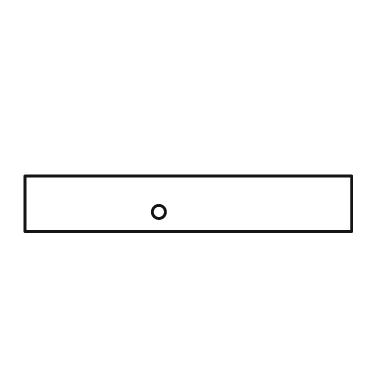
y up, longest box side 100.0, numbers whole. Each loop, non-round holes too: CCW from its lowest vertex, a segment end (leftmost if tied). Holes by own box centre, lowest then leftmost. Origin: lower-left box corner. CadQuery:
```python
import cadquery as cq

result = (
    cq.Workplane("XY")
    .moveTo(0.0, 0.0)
    .lineTo(100.0, 0.0)
    .lineTo(100.0, 17.0)
    .lineTo(0.0, 17.0)
    .close()
    .moveTo(41.0, 6.0)
    .circle(2.0)
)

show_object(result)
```